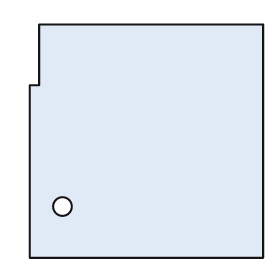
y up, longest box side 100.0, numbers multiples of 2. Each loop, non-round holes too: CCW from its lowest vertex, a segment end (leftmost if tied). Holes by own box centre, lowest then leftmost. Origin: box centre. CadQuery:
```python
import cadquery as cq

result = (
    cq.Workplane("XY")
    .moveTo(-50.0, -50.0)
    .lineTo(50.0, -50.0)
    .lineTo(50.0, 50.0)
    .lineTo(-46.0, 50.0)
    .lineTo(-46.0, 24.0)
    .lineTo(-50.0, 24.0)
    .close()
    .moveTo(-36.0, -28.0)
    .circle(4.0)
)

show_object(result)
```